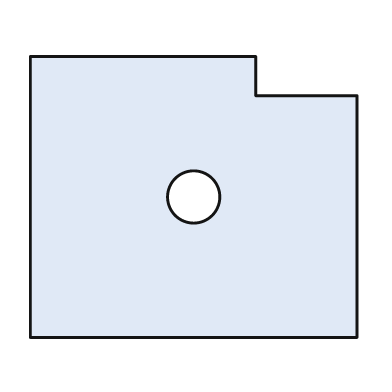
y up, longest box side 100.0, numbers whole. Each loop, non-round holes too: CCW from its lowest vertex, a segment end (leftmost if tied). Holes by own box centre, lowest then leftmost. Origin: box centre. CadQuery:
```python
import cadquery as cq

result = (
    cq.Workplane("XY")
    .moveTo(-50.0, -43.0)
    .lineTo(50.0, -43.0)
    .lineTo(50.0, 31.0)
    .lineTo(19.0, 31.0)
    .lineTo(19.0, 43.0)
    .lineTo(-50.0, 43.0)
    .close()
    .moveTo(0.0, 0.0)
    .circle(8.0)
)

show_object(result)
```